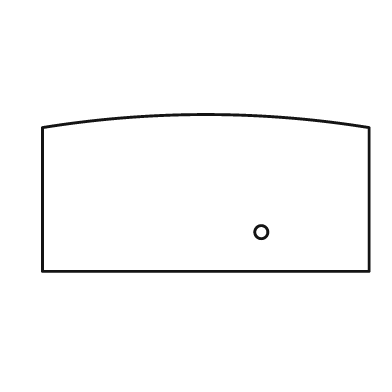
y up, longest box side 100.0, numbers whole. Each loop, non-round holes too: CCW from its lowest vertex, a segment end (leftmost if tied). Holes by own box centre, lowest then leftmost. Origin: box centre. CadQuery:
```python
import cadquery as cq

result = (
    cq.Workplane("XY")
    .moveTo(-50.0, -24.0)
    .lineTo(50.0, -24.0)
    .lineTo(50.0, 20.0)
    .threePointArc((0.0, 24.0), (-50.0, 20.0))
    .close()
    .moveTo(17.0, -12.0)
    .circle(2.0)
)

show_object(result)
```